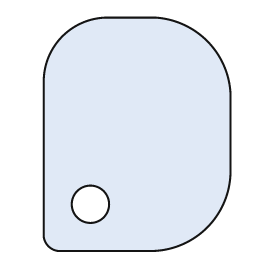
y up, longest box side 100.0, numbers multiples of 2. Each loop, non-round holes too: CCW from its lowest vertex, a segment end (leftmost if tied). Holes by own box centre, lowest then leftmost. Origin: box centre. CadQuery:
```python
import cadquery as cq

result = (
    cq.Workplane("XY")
    .moveTo(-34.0, -50.0)
    .lineTo(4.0, -50.0)
    .threePointArc((30.0, -40.0), (40.0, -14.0))
    .lineTo(40.0, 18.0)
    .threePointArc((30.0, 40.0), (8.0, 50.0))
    .lineTo(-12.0, 50.0)
    .threePointArc((-32.0, 42.0), (-40.0, 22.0))
    .lineTo(-40.0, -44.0)
    .threePointArc((-38.0, -48.0), (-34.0, -50.0))
    .close()
    .moveTo(-20.0, -30.0)
    .circle(8.0)
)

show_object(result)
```